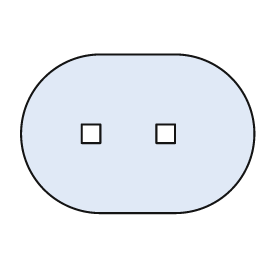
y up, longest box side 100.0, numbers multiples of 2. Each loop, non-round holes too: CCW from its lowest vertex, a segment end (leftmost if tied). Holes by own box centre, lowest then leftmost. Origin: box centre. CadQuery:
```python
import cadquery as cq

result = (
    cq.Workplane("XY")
    .moveTo(-16.0, -34.0)
    .lineTo(16.0, -34.0)
    .threePointArc((50.0, 0.0), (16.0, 34.0))
    .lineTo(-16.0, 34.0)
    .threePointArc((-50.0, 0.0), (-16.0, -34.0))
    .close()
    .moveTo(-24.0, -4.0)
    .lineTo(-16.0, -4.0)
    .lineTo(-16.0, 4.0)
    .lineTo(-24.0, 4.0)
    .close()
    .moveTo(8.0, -4.0)
    .lineTo(16.0, -4.0)
    .lineTo(16.0, 4.0)
    .lineTo(8.0, 4.0)
    .close()
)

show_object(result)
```